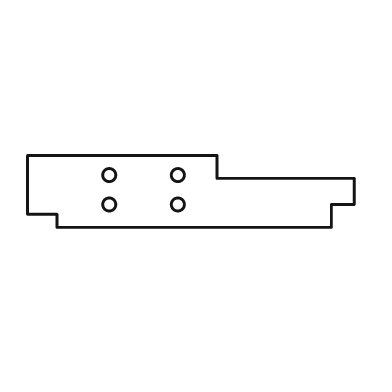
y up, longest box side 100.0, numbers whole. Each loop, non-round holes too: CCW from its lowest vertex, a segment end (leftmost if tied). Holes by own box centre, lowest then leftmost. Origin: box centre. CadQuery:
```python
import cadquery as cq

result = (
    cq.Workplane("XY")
    .moveTo(-41.0, -11.0)
    .lineTo(43.0, -11.0)
    .lineTo(43.0, -4.0)
    .lineTo(50.0, -4.0)
    .lineTo(50.0, 4.0)
    .lineTo(8.0, 4.0)
    .lineTo(8.0, 11.0)
    .lineTo(-50.0, 11.0)
    .lineTo(-50.0, -7.0)
    .lineTo(-41.0, -7.0)
    .close()
    .moveTo(-25.0, -4.0)
    .circle(2.0)
    .moveTo(-4.0, -4.0)
    .circle(2.0)
    .moveTo(-25.0, 5.0)
    .circle(2.0)
    .moveTo(-4.0, 5.0)
    .circle(2.0)
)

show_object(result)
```